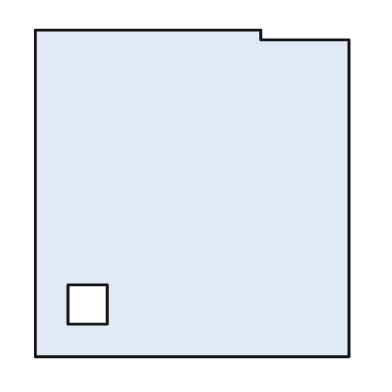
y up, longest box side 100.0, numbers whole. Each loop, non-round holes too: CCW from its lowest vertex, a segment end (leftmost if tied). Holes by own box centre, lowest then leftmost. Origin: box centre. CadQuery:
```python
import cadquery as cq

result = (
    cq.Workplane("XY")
    .moveTo(-48.0, -50.0)
    .lineTo(48.0, -50.0)
    .lineTo(48.0, 47.0)
    .lineTo(21.0, 47.0)
    .lineTo(21.0, 50.0)
    .lineTo(-48.0, 50.0)
    .close()
    .moveTo(-38.0, -40.0)
    .lineTo(-26.0, -40.0)
    .lineTo(-26.0, -28.0)
    .lineTo(-38.0, -28.0)
    .close()
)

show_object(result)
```